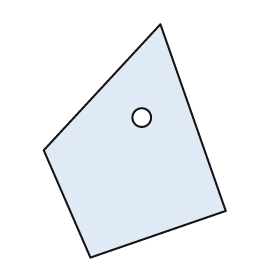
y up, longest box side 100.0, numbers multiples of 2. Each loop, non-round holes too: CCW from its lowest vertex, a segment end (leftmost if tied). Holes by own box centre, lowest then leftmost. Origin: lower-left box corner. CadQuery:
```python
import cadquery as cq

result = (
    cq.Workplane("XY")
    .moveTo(20.0, 0.0)
    .lineTo(78.0, 20.0)
    .lineTo(50.0, 100.0)
    .lineTo(0.0, 46.0)
    .close()
    .moveTo(42.0, 60.0)
    .circle(4.0)
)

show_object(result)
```